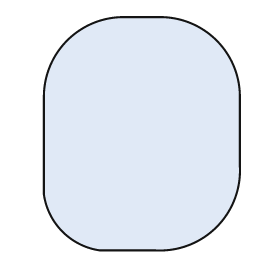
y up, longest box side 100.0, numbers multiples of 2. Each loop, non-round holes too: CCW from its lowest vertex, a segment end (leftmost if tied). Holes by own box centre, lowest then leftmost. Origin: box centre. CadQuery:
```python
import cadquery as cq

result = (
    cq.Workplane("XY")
    .moveTo(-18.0, -50.0)
    .lineTo(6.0, -50.0)
    .threePointArc((32.0, -40.0), (42.0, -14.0))
    .lineTo(42.0, 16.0)
    .threePointArc((32.0, 40.0), (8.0, 50.0))
    .lineTo(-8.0, 50.0)
    .threePointArc((-32.0, 40.0), (-42.0, 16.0))
    .lineTo(-42.0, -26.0)
    .threePointArc((-34.0, -42.0), (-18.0, -50.0))
    .close()
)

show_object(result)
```